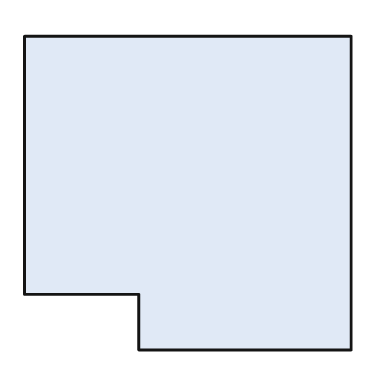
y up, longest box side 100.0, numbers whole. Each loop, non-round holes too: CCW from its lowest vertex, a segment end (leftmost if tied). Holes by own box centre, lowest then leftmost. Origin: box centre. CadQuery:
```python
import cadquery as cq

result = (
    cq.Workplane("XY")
    .moveTo(-15.0, -48.0)
    .lineTo(50.0, -48.0)
    .lineTo(50.0, 48.0)
    .lineTo(-50.0, 48.0)
    .lineTo(-50.0, -31.0)
    .lineTo(-15.0, -31.0)
    .close()
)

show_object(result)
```